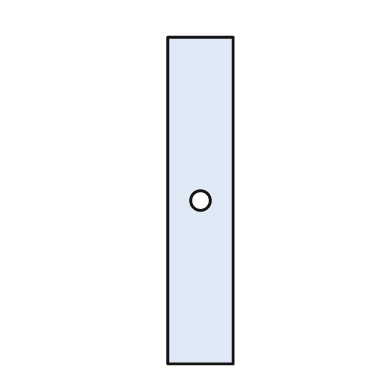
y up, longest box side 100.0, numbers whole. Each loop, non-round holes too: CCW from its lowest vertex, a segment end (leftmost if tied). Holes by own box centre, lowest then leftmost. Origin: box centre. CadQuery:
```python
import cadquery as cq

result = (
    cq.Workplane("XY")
    .moveTo(-10.0, -50.0)
    .lineTo(10.0, -50.0)
    .lineTo(10.0, 50.0)
    .lineTo(-10.0, 50.0)
    .close()
    .moveTo(0.0, 0.0)
    .circle(3.0)
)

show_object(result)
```